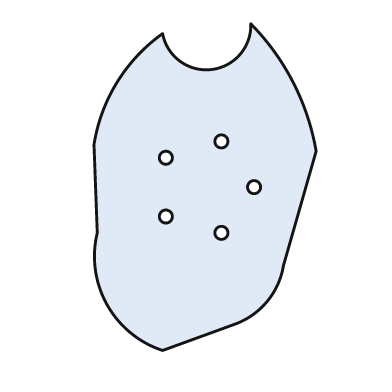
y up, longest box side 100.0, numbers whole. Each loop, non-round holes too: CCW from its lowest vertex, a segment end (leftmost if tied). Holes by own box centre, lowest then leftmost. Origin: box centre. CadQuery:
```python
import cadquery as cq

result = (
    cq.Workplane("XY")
    .moveTo(-13.0, -50.0)
    .lineTo(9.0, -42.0)
    .threePointArc((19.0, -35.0), (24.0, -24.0))
    .lineTo(34.0, 11.0)
    .threePointArc((27.0, 32.0), (14.0, 50.0))
    .threePointArc((2.0, 36.0), (-13.0, 47.0))
    .threePointArc((-27.0, 32.0), (-34.0, 13.0))
    .lineTo(-33.0, -14.0)
    .threePointArc((-30.0, -36.0), (-13.0, -50.0))
    .close()
    .moveTo(5.0, -14.0)
    .circle(2.0)
    .moveTo(-12.0, -9.0)
    .circle(2.0)
    .moveTo(15.0, 0.0)
    .circle(2.0)
    .moveTo(-12.0, 9.0)
    .circle(2.0)
    .moveTo(5.0, 14.0)
    .circle(2.0)
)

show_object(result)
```